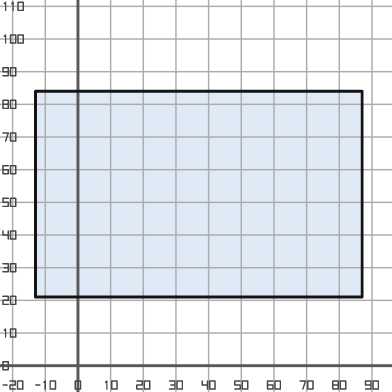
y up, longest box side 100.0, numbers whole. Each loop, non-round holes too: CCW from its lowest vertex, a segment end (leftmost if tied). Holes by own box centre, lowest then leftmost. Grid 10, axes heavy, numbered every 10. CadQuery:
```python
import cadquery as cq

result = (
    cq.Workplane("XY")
    .moveTo(-13.0, 21.0)
    .lineTo(87.0, 21.0)
    .lineTo(87.0, 84.0)
    .lineTo(-13.0, 84.0)
    .close()
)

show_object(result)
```